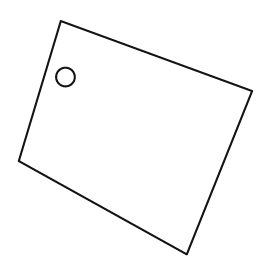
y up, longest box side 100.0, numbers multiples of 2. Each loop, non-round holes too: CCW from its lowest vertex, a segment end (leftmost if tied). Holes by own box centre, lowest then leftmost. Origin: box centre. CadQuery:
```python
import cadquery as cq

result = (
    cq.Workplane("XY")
    .moveTo(22.0, -50.0)
    .lineTo(50.0, 20.0)
    .lineTo(-32.0, 50.0)
    .lineTo(-50.0, -10.0)
    .close()
    .moveTo(-30.0, 26.0)
    .circle(4.0)
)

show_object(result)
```